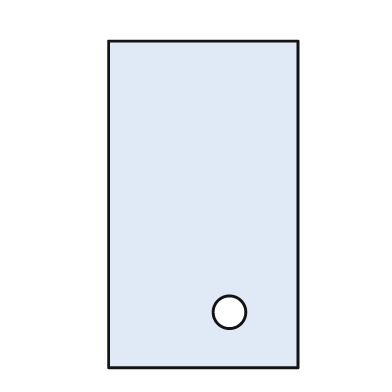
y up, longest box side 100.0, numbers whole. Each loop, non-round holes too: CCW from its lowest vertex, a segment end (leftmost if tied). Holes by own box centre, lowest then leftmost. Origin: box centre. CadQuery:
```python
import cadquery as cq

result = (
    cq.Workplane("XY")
    .moveTo(-29.0, -50.0)
    .lineTo(29.0, -50.0)
    .lineTo(29.0, 50.0)
    .lineTo(-29.0, 50.0)
    .close()
    .moveTo(8.0, -33.0)
    .circle(5.0)
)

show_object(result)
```